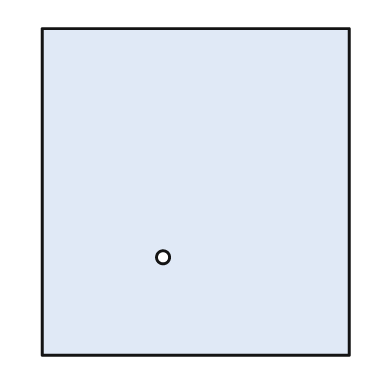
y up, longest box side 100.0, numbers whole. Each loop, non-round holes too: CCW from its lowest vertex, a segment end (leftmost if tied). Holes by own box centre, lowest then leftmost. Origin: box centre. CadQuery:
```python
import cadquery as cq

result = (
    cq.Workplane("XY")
    .moveTo(-47.0, -50.0)
    .lineTo(47.0, -50.0)
    .lineTo(47.0, 50.0)
    .lineTo(-47.0, 50.0)
    .close()
    .moveTo(-10.0, -20.0)
    .circle(2.0)
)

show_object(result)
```